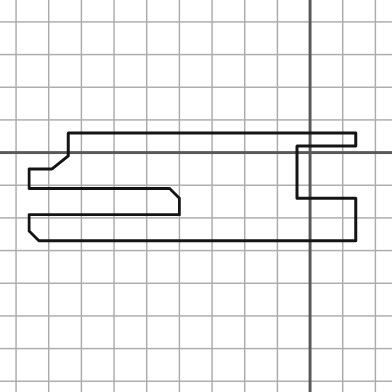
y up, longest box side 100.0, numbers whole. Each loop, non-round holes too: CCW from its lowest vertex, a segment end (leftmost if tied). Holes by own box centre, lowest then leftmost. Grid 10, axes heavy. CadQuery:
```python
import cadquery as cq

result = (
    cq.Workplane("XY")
    .moveTo(-83.0, -27.0)
    .lineTo(14.0, -27.0)
    .lineTo(14.0, -14.0)
    .lineTo(-4.0, -14.0)
    .lineTo(-4.0, 2.0)
    .lineTo(14.0, 2.0)
    .lineTo(14.0, 6.0)
    .lineTo(-74.0, 6.0)
    .lineTo(-74.0, -1.0)
    .lineTo(-79.0, -5.0)
    .lineTo(-86.0, -5.0)
    .lineTo(-86.0, -11.0)
    .lineTo(-43.0, -11.0)
    .lineTo(-40.0, -14.0)
    .lineTo(-40.0, -19.0)
    .lineTo(-86.0, -19.0)
    .lineTo(-86.0, -24.0)
    .close()
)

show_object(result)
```